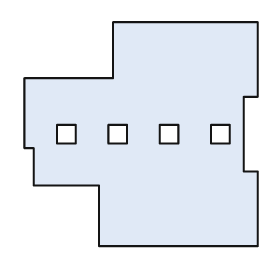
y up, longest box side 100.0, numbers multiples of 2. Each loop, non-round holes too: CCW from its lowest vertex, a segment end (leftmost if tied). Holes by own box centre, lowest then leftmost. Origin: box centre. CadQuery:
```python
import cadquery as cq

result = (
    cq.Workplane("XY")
    .moveTo(-18.0, -48.0)
    .lineTo(50.0, -48.0)
    .lineTo(50.0, -16.0)
    .lineTo(44.0, -16.0)
    .lineTo(44.0, 16.0)
    .lineTo(50.0, 16.0)
    .lineTo(50.0, 48.0)
    .lineTo(-12.0, 48.0)
    .lineTo(-12.0, 24.0)
    .lineTo(-50.0, 24.0)
    .lineTo(-50.0, -6.0)
    .lineTo(-46.0, -6.0)
    .lineTo(-46.0, -22.0)
    .lineTo(-18.0, -22.0)
    .close()
    .moveTo(-36.0, -4.0)
    .lineTo(-28.0, -4.0)
    .lineTo(-28.0, 4.0)
    .lineTo(-36.0, 4.0)
    .close()
    .moveTo(-14.0, -4.0)
    .lineTo(-6.0, -4.0)
    .lineTo(-6.0, 4.0)
    .lineTo(-14.0, 4.0)
    .close()
    .moveTo(8.0, -4.0)
    .lineTo(16.0, -4.0)
    .lineTo(16.0, 4.0)
    .lineTo(8.0, 4.0)
    .close()
    .moveTo(30.0, -4.0)
    .lineTo(38.0, -4.0)
    .lineTo(38.0, 4.0)
    .lineTo(30.0, 4.0)
    .close()
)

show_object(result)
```